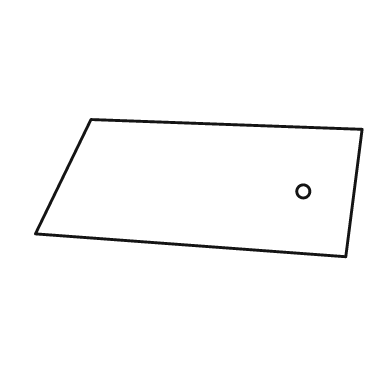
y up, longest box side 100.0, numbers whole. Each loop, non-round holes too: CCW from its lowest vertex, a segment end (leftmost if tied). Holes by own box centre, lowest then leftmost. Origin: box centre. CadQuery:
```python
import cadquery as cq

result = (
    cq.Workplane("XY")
    .moveTo(45.0, -21.0)
    .lineTo(50.0, 18.0)
    .lineTo(-33.0, 21.0)
    .lineTo(-50.0, -14.0)
    .close()
    .moveTo(32.0, -1.0)
    .circle(2.0)
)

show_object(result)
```